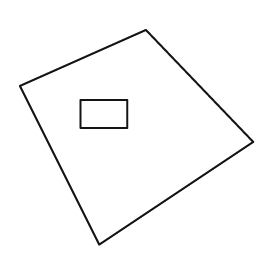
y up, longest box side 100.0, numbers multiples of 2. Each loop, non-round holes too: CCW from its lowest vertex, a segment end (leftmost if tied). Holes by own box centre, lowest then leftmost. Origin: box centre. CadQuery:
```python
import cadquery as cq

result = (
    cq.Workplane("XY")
    .moveTo(-16.0, -46.0)
    .lineTo(50.0, -2.0)
    .lineTo(4.0, 46.0)
    .lineTo(-50.0, 22.0)
    .close()
    .moveTo(-24.0, 4.0)
    .lineTo(-4.0, 4.0)
    .lineTo(-4.0, 16.0)
    .lineTo(-24.0, 16.0)
    .close()
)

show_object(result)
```